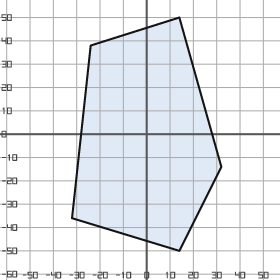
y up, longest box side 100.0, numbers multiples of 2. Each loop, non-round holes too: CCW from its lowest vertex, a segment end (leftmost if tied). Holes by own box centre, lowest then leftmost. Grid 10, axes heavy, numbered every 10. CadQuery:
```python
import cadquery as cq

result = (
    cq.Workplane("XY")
    .moveTo(14.0, -50.0)
    .lineTo(32.0, -14.0)
    .lineTo(14.0, 50.0)
    .lineTo(-24.0, 38.0)
    .lineTo(-32.0, -36.0)
    .close()
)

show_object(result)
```